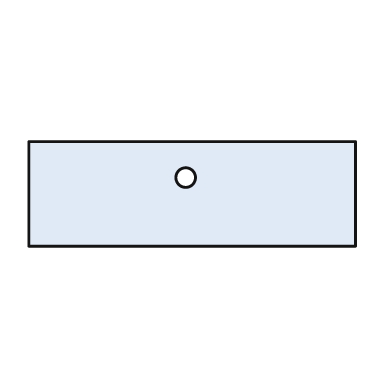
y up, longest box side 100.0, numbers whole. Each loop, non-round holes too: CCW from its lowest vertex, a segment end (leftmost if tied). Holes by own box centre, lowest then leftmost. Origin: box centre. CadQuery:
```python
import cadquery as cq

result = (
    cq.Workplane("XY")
    .moveTo(-50.0, -16.0)
    .lineTo(50.0, -16.0)
    .lineTo(50.0, 16.0)
    .lineTo(-50.0, 16.0)
    .close()
    .moveTo(-2.0, 5.0)
    .circle(3.0)
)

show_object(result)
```